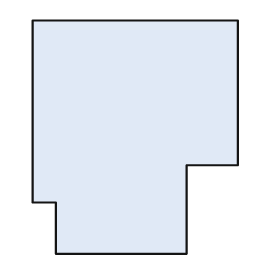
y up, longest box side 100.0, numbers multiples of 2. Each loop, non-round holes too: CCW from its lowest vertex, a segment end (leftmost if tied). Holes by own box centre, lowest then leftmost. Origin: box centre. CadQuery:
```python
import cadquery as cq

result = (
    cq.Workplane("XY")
    .moveTo(-34.0, -50.0)
    .lineTo(22.0, -50.0)
    .lineTo(22.0, -12.0)
    .lineTo(44.0, -12.0)
    .lineTo(44.0, 50.0)
    .lineTo(-44.0, 50.0)
    .lineTo(-44.0, -28.0)
    .lineTo(-34.0, -28.0)
    .close()
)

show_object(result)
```